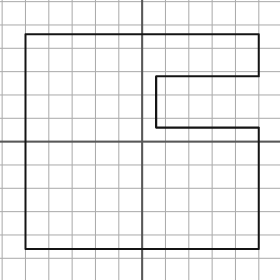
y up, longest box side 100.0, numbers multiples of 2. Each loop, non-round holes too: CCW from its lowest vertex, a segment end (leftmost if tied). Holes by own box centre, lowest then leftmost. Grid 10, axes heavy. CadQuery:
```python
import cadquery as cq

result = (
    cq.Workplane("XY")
    .moveTo(-50.0, -46.0)
    .lineTo(50.0, -46.0)
    .lineTo(50.0, 6.0)
    .lineTo(6.0, 6.0)
    .lineTo(6.0, 28.0)
    .lineTo(50.0, 28.0)
    .lineTo(50.0, 46.0)
    .lineTo(-50.0, 46.0)
    .close()
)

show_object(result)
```